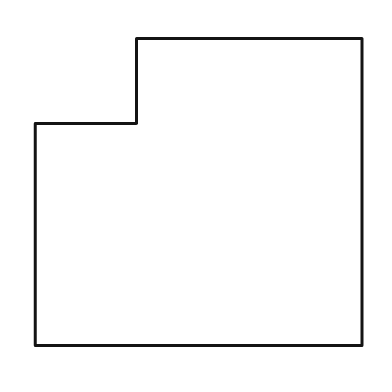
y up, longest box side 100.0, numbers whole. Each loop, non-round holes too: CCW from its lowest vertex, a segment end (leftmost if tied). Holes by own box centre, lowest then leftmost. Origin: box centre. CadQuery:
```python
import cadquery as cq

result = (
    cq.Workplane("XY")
    .moveTo(-50.0, -47.0)
    .lineTo(50.0, -47.0)
    .lineTo(50.0, 47.0)
    .lineTo(-19.0, 47.0)
    .lineTo(-19.0, 21.0)
    .lineTo(-50.0, 21.0)
    .close()
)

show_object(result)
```